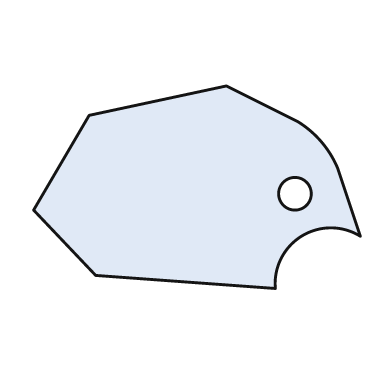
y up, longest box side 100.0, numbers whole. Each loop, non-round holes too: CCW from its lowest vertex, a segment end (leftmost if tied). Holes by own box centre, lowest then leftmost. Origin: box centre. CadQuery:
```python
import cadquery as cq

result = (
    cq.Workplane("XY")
    .moveTo(24.0, -31.0)
    .threePointArc((32.0, -15.0), (50.0, -15.0))
    .lineTo(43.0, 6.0)
    .threePointArc((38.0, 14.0), (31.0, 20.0))
    .lineTo(9.0, 31.0)
    .lineTo(-33.0, 22.0)
    .lineTo(-50.0, -7.0)
    .lineTo(-31.0, -27.0)
    .close()
    .moveTo(30.0, -2.0)
    .circle(5.0)
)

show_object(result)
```